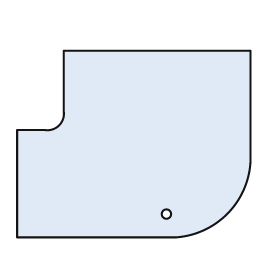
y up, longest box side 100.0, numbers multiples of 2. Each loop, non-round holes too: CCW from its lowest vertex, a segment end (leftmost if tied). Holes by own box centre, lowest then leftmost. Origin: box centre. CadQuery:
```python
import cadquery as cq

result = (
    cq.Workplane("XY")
    .moveTo(-50.0, -40.0)
    .lineTo(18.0, -40.0)
    .threePointArc((40.0, -30.0), (50.0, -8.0))
    .lineTo(50.0, 40.0)
    .lineTo(-30.0, 40.0)
    .lineTo(-30.0, 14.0)
    .threePointArc((-32.0, 8.0), (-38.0, 6.0))
    .lineTo(-50.0, 6.0)
    .close()
    .moveTo(14.0, -30.0)
    .circle(2.0)
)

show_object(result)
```